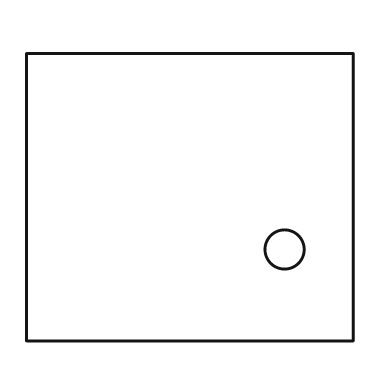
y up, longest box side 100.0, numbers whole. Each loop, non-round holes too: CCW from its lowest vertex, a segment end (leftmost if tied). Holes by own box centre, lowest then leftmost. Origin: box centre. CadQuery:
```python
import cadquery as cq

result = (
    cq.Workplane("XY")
    .moveTo(-50.0, -44.0)
    .lineTo(50.0, -44.0)
    .lineTo(50.0, 44.0)
    .lineTo(-50.0, 44.0)
    .close()
    .moveTo(29.0, -16.0)
    .circle(6.0)
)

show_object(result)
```